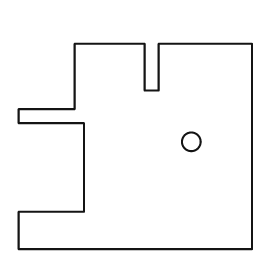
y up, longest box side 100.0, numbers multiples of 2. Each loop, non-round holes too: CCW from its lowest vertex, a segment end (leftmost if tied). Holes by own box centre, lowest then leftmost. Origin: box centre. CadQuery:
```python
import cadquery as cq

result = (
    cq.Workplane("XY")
    .moveTo(-50.0, -44.0)
    .lineTo(50.0, -44.0)
    .lineTo(50.0, 44.0)
    .lineTo(10.0, 44.0)
    .lineTo(10.0, 24.0)
    .lineTo(4.0, 24.0)
    .lineTo(4.0, 44.0)
    .lineTo(-26.0, 44.0)
    .lineTo(-26.0, 16.0)
    .lineTo(-50.0, 16.0)
    .lineTo(-50.0, 10.0)
    .lineTo(-22.0, 10.0)
    .lineTo(-22.0, -28.0)
    .lineTo(-50.0, -28.0)
    .close()
    .moveTo(24.0, 2.0)
    .circle(4.0)
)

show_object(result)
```